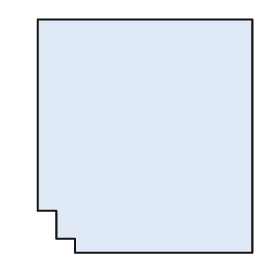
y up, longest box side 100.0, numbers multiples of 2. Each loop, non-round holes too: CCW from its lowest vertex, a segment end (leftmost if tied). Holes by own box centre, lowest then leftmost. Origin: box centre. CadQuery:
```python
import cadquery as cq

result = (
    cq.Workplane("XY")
    .moveTo(-30.0, -50.0)
    .lineTo(46.0, -50.0)
    .lineTo(46.0, 50.0)
    .lineTo(-46.0, 50.0)
    .lineTo(-46.0, -32.0)
    .lineTo(-38.0, -32.0)
    .lineTo(-38.0, -44.0)
    .lineTo(-30.0, -44.0)
    .close()
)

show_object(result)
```